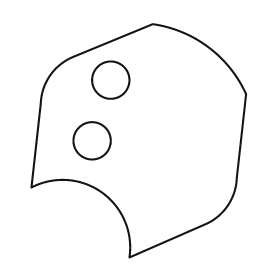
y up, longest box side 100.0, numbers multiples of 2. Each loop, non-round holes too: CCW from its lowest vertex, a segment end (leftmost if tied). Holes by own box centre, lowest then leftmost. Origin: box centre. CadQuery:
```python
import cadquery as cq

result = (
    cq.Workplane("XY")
    .moveTo(-4.0, -50.0)
    .lineTo(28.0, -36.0)
    .threePointArc((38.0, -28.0), (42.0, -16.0))
    .lineTo(46.0, 20.0)
    .threePointArc((30.0, 40.0), (6.0, 50.0))
    .lineTo(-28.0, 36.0)
    .threePointArc((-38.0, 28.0), (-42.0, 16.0))
    .lineTo(-46.0, -20.0)
    .threePointArc((-16.0, -22.0), (-4.0, -50.0))
    .close()
    .moveTo(-20.0, 0.0)
    .circle(8.0)
    .moveTo(-12.0, 26.0)
    .circle(8.0)
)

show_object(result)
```